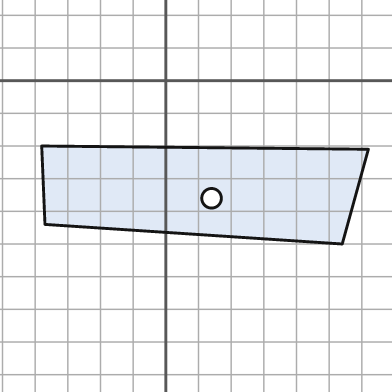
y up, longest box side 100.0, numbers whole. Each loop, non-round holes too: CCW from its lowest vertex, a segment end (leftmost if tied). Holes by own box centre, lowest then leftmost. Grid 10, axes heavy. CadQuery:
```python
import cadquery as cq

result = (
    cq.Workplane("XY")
    .moveTo(54.0, -50.0)
    .lineTo(62.0, -21.0)
    .lineTo(-38.0, -20.0)
    .lineTo(-37.0, -44.0)
    .close()
    .moveTo(14.0, -36.0)
    .circle(3.0)
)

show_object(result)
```